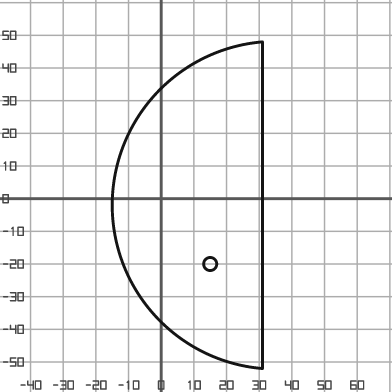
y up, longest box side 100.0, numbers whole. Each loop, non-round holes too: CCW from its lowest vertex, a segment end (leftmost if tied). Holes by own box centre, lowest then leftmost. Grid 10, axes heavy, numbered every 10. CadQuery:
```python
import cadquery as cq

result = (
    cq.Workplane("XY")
    .moveTo(31.0, -52.0)
    .lineTo(31.0, 48.0)
    .threePointArc((-15.0, -2.0), (31.0, -52.0))
    .close()
    .moveTo(15.0, -20.0)
    .circle(2.0)
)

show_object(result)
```